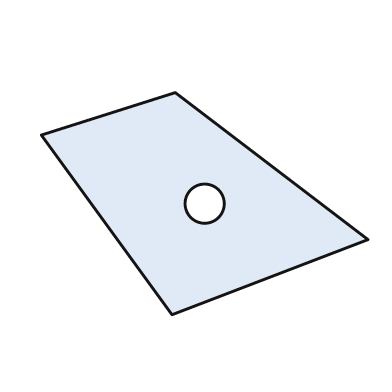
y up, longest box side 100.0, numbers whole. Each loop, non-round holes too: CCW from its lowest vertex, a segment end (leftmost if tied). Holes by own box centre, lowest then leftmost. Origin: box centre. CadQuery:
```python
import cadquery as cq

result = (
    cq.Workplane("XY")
    .moveTo(-10.0, -34.0)
    .lineTo(50.0, -11.0)
    .lineTo(-9.0, 34.0)
    .lineTo(-50.0, 21.0)
    .close()
    .moveTo(0.0, 0.0)
    .circle(6.0)
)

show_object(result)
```